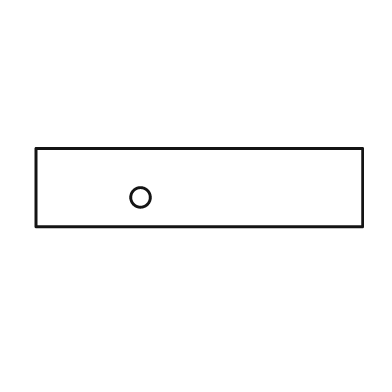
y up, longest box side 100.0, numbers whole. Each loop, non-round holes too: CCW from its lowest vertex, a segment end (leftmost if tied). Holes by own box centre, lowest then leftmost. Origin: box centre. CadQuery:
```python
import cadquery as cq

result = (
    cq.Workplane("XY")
    .moveTo(-50.0, -12.0)
    .lineTo(50.0, -12.0)
    .lineTo(50.0, 12.0)
    .lineTo(-50.0, 12.0)
    .close()
    .moveTo(-18.0, -3.0)
    .circle(3.0)
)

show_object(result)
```